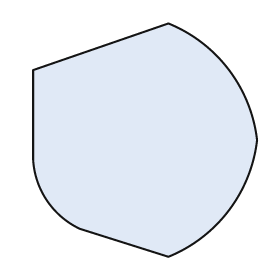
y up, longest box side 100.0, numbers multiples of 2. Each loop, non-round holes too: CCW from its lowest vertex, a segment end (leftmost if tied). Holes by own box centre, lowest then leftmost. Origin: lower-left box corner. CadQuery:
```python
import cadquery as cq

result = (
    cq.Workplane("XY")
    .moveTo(58.0, 0.0)
    .threePointArc((84.0, 20.0), (96.0, 50.0))
    .threePointArc((84.0, 80.0), (58.0, 100.0))
    .lineTo(0.0, 80.0)
    .lineTo(0.0, 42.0)
    .threePointArc((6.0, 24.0), (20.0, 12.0))
    .close()
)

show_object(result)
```